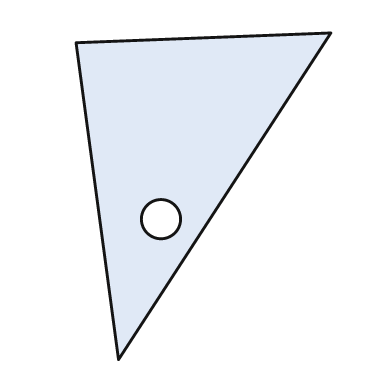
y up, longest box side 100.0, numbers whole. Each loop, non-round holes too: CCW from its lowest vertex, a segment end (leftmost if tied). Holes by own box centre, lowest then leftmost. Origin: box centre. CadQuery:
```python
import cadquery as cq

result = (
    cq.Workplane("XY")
    .moveTo(-26.0, -50.0)
    .lineTo(39.0, 50.0)
    .lineTo(-39.0, 47.0)
    .close()
    .moveTo(-13.0, -7.0)
    .circle(6.0)
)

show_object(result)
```